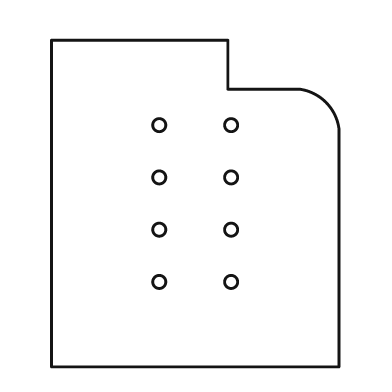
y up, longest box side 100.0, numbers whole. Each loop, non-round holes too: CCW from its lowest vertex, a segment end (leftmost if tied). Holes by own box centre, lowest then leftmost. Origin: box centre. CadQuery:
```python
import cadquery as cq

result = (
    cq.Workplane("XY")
    .moveTo(-44.0, -50.0)
    .lineTo(44.0, -50.0)
    .lineTo(44.0, 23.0)
    .threePointArc((40.0, 31.0), (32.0, 35.0))
    .lineTo(10.0, 35.0)
    .lineTo(10.0, 50.0)
    .lineTo(-44.0, 50.0)
    .close()
    .moveTo(-11.0, -24.0)
    .circle(2.0)
    .moveTo(11.0, -24.0)
    .circle(2.0)
    .moveTo(-11.0, -8.0)
    .circle(2.0)
    .moveTo(11.0, -8.0)
    .circle(2.0)
    .moveTo(-11.0, 8.0)
    .circle(2.0)
    .moveTo(11.0, 8.0)
    .circle(2.0)
    .moveTo(-11.0, 24.0)
    .circle(2.0)
    .moveTo(11.0, 24.0)
    .circle(2.0)
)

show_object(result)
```